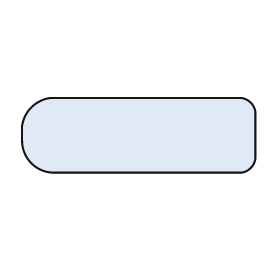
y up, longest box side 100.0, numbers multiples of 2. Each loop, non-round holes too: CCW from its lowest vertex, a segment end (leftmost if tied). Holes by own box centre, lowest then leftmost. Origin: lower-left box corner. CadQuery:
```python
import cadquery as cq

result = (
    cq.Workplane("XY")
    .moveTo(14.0, 0.0)
    .lineTo(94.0, 0.0)
    .threePointArc((98.0, 2.0), (100.0, 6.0))
    .lineTo(100.0, 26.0)
    .threePointArc((98.0, 30.0), (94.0, 32.0))
    .lineTo(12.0, 32.0)
    .threePointArc((4.0, 28.0), (0.0, 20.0))
    .lineTo(0.0, 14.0)
    .threePointArc((4.0, 4.0), (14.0, 0.0))
    .close()
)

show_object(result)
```